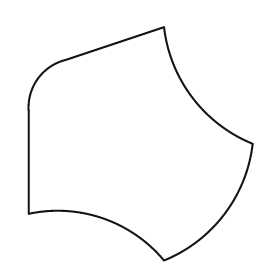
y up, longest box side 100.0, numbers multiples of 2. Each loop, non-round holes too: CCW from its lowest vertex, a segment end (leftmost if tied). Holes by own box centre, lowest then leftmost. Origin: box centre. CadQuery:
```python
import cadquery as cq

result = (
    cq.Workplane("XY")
    .moveTo(10.0, -50.0)
    .threePointArc((36.0, -30.0), (48.0, 0.0))
    .threePointArc((22.0, 20.0), (10.0, 50.0))
    .lineTo(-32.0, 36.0)
    .threePointArc((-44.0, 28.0), (-48.0, 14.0))
    .lineTo(-48.0, -30.0)
    .threePointArc((-16.0, -32.0), (10.0, -50.0))
    .close()
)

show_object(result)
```